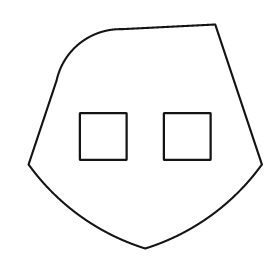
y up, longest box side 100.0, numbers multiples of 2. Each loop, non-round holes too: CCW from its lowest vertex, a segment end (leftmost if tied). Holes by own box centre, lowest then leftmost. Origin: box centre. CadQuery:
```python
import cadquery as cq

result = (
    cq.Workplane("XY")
    .moveTo(0.0, -48.0)
    .threePointArc((28.0, -34.0), (50.0, -12.0))
    .lineTo(30.0, 48.0)
    .lineTo(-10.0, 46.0)
    .threePointArc((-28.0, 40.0), (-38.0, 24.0))
    .lineTo(-50.0, -12.0)
    .threePointArc((-28.0, -34.0), (0.0, -48.0))
    .close()
    .moveTo(-28.0, -10.0)
    .lineTo(-8.0, -10.0)
    .lineTo(-8.0, 10.0)
    .lineTo(-28.0, 10.0)
    .close()
    .moveTo(8.0, -10.0)
    .lineTo(28.0, -10.0)
    .lineTo(28.0, 10.0)
    .lineTo(8.0, 10.0)
    .close()
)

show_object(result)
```